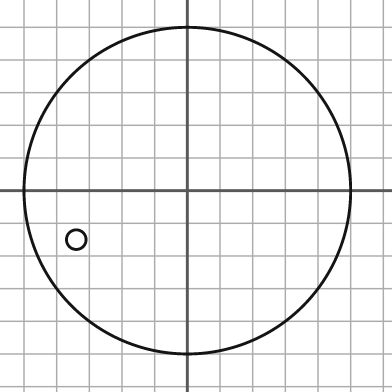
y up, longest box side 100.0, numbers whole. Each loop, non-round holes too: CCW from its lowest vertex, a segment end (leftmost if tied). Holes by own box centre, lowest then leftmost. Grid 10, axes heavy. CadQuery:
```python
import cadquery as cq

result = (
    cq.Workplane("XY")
    .moveTo(0.0, 0.0)
    .circle(50.0)
    .moveTo(-34.0, -15.0)
    .circle(3.0)
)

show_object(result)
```